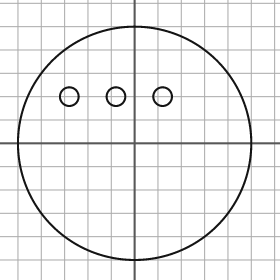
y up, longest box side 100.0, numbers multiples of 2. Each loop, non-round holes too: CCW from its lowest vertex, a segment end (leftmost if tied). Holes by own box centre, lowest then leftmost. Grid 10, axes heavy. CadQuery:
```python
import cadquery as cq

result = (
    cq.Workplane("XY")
    .moveTo(0.0, 0.0)
    .circle(50.0)
    .moveTo(-28.0, 20.0)
    .circle(4.0)
    .moveTo(-8.0, 20.0)
    .circle(4.0)
    .moveTo(12.0, 20.0)
    .circle(4.0)
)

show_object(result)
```